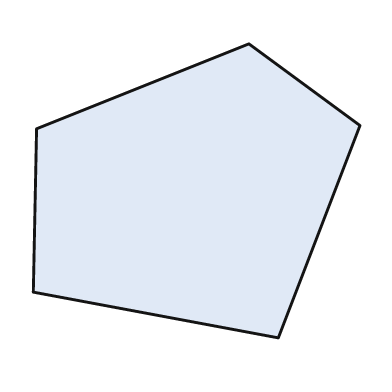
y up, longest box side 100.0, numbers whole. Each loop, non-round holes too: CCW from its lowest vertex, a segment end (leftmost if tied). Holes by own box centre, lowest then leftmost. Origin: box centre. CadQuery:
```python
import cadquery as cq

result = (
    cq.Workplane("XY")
    .moveTo(25.0, -45.0)
    .lineTo(50.0, 20.0)
    .lineTo(16.0, 45.0)
    .lineTo(-49.0, 19.0)
    .lineTo(-50.0, -31.0)
    .close()
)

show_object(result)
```